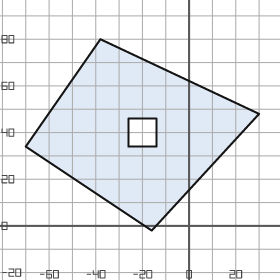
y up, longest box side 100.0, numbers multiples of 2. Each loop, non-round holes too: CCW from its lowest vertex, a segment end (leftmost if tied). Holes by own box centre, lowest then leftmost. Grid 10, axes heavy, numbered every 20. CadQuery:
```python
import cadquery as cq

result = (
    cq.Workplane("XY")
    .moveTo(-16.0, -2.0)
    .lineTo(30.0, 48.0)
    .lineTo(-38.0, 80.0)
    .lineTo(-70.0, 34.0)
    .close()
    .moveTo(-26.0, 34.0)
    .lineTo(-14.0, 34.0)
    .lineTo(-14.0, 46.0)
    .lineTo(-26.0, 46.0)
    .close()
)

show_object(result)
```